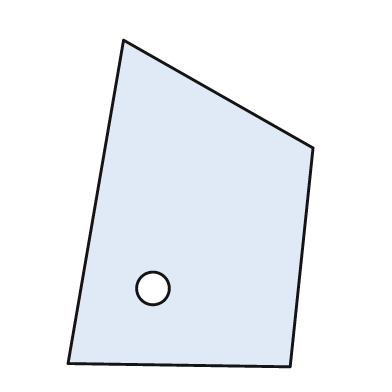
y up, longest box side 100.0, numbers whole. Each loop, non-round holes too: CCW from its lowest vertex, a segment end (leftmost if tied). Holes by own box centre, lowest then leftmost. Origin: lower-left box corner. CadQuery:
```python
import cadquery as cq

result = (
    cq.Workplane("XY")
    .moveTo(68.0, 0.0)
    .lineTo(75.0, 67.0)
    .lineTo(17.0, 100.0)
    .lineTo(0.0, 1.0)
    .close()
    .moveTo(26.0, 24.0)
    .circle(5.0)
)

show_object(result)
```